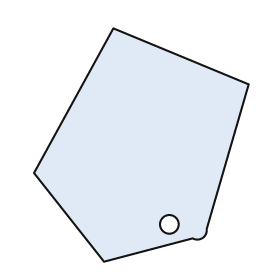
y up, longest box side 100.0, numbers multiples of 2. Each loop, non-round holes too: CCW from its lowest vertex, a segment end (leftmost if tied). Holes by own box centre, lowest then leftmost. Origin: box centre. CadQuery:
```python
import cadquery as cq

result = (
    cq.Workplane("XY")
    .moveTo(-16.0, -50.0)
    .lineTo(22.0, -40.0)
    .threePointArc((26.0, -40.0), (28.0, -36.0))
    .lineTo(46.0, 26.0)
    .lineTo(-12.0, 50.0)
    .lineTo(-46.0, -12.0)
    .close()
    .moveTo(12.0, -34.0)
    .circle(4.0)
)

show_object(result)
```